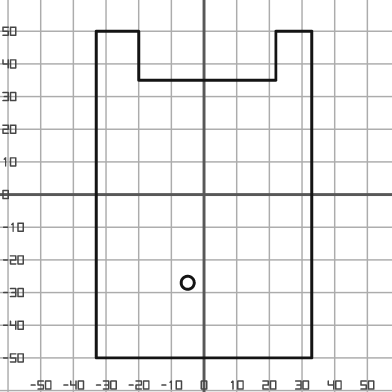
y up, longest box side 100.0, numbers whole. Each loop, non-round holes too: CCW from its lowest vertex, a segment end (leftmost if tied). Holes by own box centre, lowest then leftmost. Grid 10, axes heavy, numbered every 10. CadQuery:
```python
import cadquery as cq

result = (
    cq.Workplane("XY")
    .moveTo(-33.0, -50.0)
    .lineTo(33.0, -50.0)
    .lineTo(33.0, 50.0)
    .lineTo(22.0, 50.0)
    .lineTo(22.0, 35.0)
    .lineTo(-20.0, 35.0)
    .lineTo(-20.0, 50.0)
    .lineTo(-33.0, 50.0)
    .close()
    .moveTo(-5.0, -27.0)
    .circle(2.0)
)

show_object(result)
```